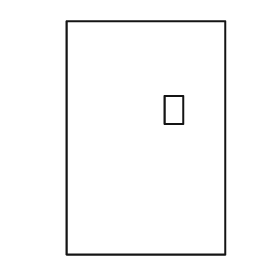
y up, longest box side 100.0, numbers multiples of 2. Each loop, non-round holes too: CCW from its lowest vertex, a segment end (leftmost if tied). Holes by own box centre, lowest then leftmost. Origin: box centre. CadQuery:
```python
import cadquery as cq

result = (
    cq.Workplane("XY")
    .moveTo(-34.0, -50.0)
    .lineTo(34.0, -50.0)
    .lineTo(34.0, 50.0)
    .lineTo(-34.0, 50.0)
    .close()
    .moveTo(8.0, 6.0)
    .lineTo(16.0, 6.0)
    .lineTo(16.0, 18.0)
    .lineTo(8.0, 18.0)
    .close()
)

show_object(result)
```